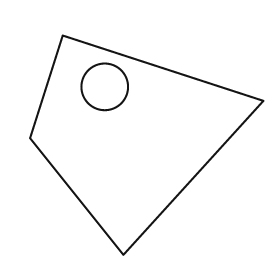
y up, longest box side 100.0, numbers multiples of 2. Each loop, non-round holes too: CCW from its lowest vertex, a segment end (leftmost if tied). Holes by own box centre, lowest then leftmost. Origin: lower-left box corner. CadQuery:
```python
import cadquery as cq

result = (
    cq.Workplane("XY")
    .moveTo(40.0, 0.0)
    .lineTo(100.0, 66.0)
    .lineTo(14.0, 94.0)
    .lineTo(0.0, 50.0)
    .close()
    .moveTo(32.0, 72.0)
    .circle(10.0)
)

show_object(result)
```